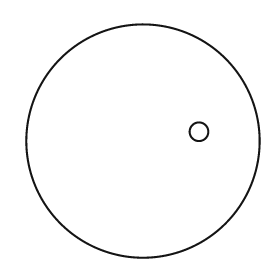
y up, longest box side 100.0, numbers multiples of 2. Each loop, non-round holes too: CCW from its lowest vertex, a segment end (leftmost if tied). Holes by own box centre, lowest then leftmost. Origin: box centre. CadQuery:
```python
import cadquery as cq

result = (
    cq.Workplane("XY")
    .moveTo(0.0, 0.0)
    .circle(50.0)
    .moveTo(24.0, 4.0)
    .circle(4.0)
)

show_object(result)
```